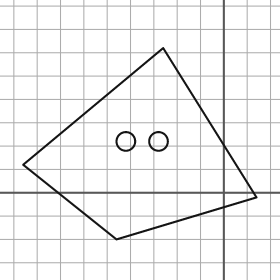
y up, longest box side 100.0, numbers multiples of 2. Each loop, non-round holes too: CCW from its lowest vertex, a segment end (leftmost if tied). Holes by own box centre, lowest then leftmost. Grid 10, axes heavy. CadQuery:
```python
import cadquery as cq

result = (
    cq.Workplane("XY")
    .moveTo(-46.0, -20.0)
    .lineTo(14.0, -2.0)
    .lineTo(-26.0, 62.0)
    .lineTo(-86.0, 12.0)
    .close()
    .moveTo(-42.0, 22.0)
    .circle(4.0)
    .moveTo(-28.0, 22.0)
    .circle(4.0)
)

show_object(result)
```